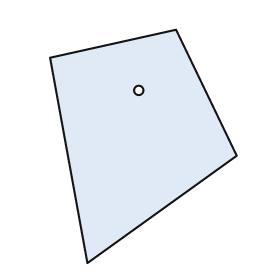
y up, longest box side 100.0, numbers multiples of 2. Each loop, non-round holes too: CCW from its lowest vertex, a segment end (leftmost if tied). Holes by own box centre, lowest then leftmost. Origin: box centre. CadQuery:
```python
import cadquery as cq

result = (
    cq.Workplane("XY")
    .moveTo(-24.0, -50.0)
    .lineTo(40.0, -4.0)
    .lineTo(14.0, 50.0)
    .lineTo(-40.0, 38.0)
    .close()
    .moveTo(-2.0, 24.0)
    .circle(2.0)
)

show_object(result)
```